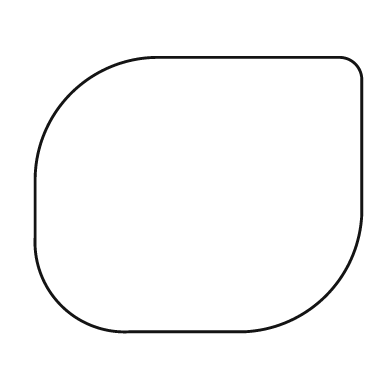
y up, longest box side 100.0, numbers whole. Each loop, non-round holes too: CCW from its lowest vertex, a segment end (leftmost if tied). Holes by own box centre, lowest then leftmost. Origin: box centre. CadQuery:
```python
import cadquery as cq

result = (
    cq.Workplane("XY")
    .moveTo(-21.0, -42.0)
    .lineTo(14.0, -42.0)
    .threePointArc((39.0, -31.0), (50.0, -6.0))
    .lineTo(50.0, 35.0)
    .threePointArc((48.0, 40.0), (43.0, 42.0))
    .lineTo(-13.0, 42.0)
    .threePointArc((-39.0, 31.0), (-50.0, 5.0))
    .lineTo(-50.0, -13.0)
    .threePointArc((-42.0, -34.0), (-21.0, -42.0))
    .close()
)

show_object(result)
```